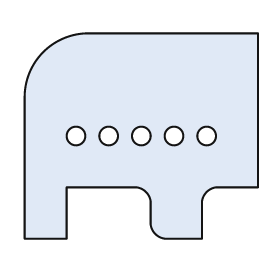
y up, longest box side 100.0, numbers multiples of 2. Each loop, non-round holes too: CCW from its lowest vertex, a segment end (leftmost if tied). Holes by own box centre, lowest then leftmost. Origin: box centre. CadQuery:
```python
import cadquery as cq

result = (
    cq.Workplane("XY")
    .moveTo(-50.0, -44.0)
    .lineTo(-32.0, -44.0)
    .lineTo(-32.0, -22.0)
    .lineTo(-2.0, -22.0)
    .threePointArc((2.0, -24.0), (4.0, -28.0))
    .lineTo(4.0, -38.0)
    .threePointArc((6.0, -42.0), (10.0, -44.0))
    .lineTo(26.0, -44.0)
    .lineTo(26.0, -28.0)
    .threePointArc((28.0, -24.0), (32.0, -22.0))
    .lineTo(50.0, -22.0)
    .lineTo(50.0, 44.0)
    .lineTo(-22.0, 44.0)
    .threePointArc((-42.0, 36.0), (-50.0, 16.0))
    .close()
    .moveTo(-28.0, 0.0)
    .circle(4.0)
    .moveTo(-14.0, 0.0)
    .circle(4.0)
    .moveTo(0.0, 0.0)
    .circle(4.0)
    .moveTo(14.0, 0.0)
    .circle(4.0)
    .moveTo(28.0, 0.0)
    .circle(4.0)
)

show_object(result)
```